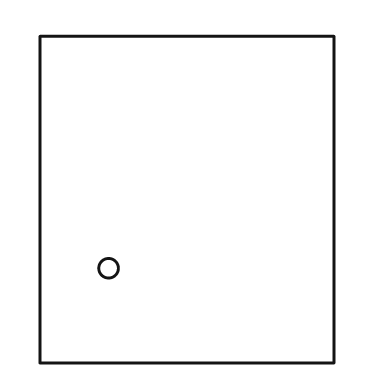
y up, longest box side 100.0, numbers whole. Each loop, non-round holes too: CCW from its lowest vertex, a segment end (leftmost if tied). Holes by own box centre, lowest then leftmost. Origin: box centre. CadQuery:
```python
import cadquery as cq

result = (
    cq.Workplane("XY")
    .moveTo(-45.0, -50.0)
    .lineTo(45.0, -50.0)
    .lineTo(45.0, 50.0)
    .lineTo(-45.0, 50.0)
    .close()
    .moveTo(-24.0, -21.0)
    .circle(3.0)
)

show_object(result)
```